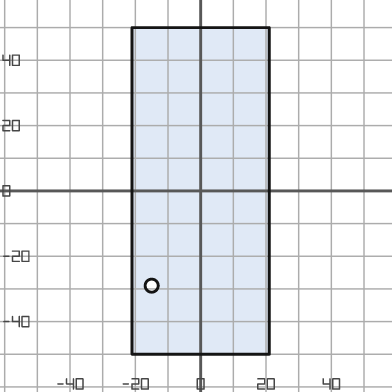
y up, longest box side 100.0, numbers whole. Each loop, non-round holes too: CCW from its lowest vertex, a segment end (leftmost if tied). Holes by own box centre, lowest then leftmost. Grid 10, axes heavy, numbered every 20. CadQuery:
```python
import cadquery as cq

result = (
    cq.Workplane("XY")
    .moveTo(-21.0, -50.0)
    .lineTo(21.0, -50.0)
    .lineTo(21.0, 50.0)
    .lineTo(-21.0, 50.0)
    .close()
    .moveTo(-15.0, -29.0)
    .circle(2.0)
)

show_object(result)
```